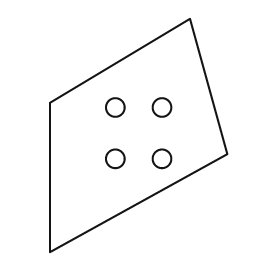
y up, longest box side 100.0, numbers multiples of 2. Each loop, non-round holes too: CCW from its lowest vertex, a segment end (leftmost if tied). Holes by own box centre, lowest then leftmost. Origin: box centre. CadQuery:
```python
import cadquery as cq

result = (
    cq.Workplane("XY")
    .moveTo(-38.0, -50.0)
    .lineTo(38.0, -8.0)
    .lineTo(22.0, 50.0)
    .lineTo(-38.0, 14.0)
    .close()
    .moveTo(-10.0, -10.0)
    .circle(4.0)
    .moveTo(10.0, -10.0)
    .circle(4.0)
    .moveTo(-10.0, 12.0)
    .circle(4.0)
    .moveTo(10.0, 12.0)
    .circle(4.0)
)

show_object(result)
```